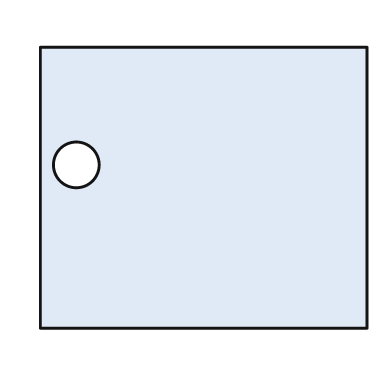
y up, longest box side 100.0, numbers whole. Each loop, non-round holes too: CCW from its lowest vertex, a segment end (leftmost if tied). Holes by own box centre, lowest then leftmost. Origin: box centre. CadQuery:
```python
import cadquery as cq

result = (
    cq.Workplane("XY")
    .moveTo(-50.0, -43.0)
    .lineTo(50.0, -43.0)
    .lineTo(50.0, 43.0)
    .lineTo(-50.0, 43.0)
    .close()
    .moveTo(-39.0, 7.0)
    .circle(7.0)
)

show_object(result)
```